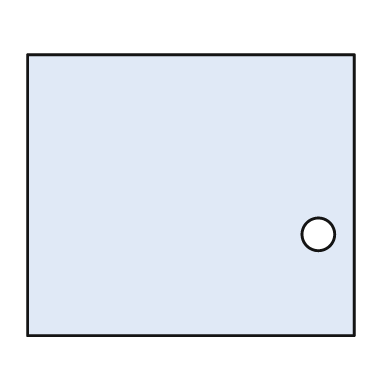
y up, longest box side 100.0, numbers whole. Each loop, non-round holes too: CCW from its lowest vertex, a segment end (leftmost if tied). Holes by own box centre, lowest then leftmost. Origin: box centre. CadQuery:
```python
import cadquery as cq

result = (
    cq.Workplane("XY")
    .moveTo(-50.0, -43.0)
    .lineTo(50.0, -43.0)
    .lineTo(50.0, 43.0)
    .lineTo(-50.0, 43.0)
    .close()
    .moveTo(39.0, -12.0)
    .circle(5.0)
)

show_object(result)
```